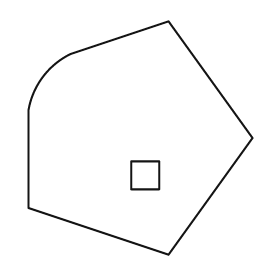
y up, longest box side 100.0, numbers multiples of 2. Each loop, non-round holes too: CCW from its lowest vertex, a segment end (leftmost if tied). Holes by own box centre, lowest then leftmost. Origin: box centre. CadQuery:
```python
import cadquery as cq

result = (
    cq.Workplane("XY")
    .moveTo(12.0, -50.0)
    .lineTo(48.0, 0.0)
    .lineTo(12.0, 50.0)
    .lineTo(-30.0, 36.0)
    .threePointArc((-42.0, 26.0), (-48.0, 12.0))
    .lineTo(-48.0, -30.0)
    .close()
    .moveTo(-4.0, -22.0)
    .lineTo(8.0, -22.0)
    .lineTo(8.0, -10.0)
    .lineTo(-4.0, -10.0)
    .close()
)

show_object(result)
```